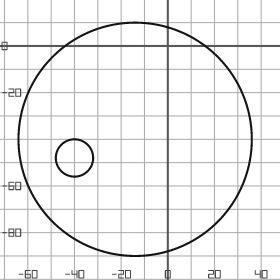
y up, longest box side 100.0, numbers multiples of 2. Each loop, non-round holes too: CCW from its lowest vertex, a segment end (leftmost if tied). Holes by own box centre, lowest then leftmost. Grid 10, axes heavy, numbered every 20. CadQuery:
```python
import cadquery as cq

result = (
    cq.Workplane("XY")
    .moveTo(-14.0, -40.0)
    .circle(50.0)
    .moveTo(-40.0, -48.0)
    .circle(8.0)
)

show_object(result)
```